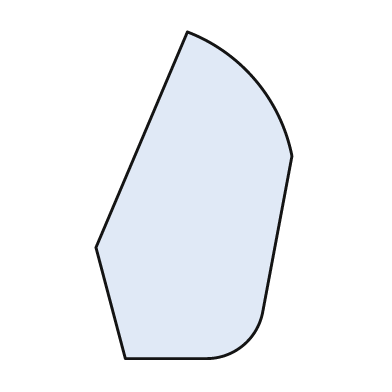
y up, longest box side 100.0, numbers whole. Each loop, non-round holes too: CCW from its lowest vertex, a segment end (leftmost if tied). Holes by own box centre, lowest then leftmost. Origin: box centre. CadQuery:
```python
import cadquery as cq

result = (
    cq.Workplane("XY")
    .moveTo(-21.0, -50.0)
    .lineTo(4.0, -50.0)
    .threePointArc((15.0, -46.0), (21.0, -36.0))
    .lineTo(30.0, 12.0)
    .threePointArc((19.0, 35.0), (-2.0, 50.0))
    .lineTo(-30.0, -16.0)
    .close()
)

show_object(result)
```